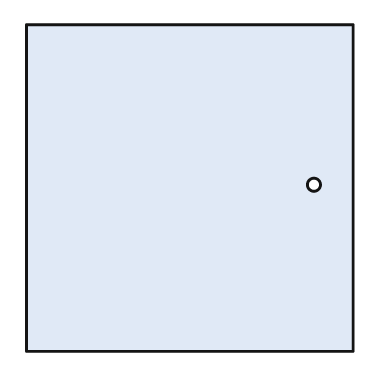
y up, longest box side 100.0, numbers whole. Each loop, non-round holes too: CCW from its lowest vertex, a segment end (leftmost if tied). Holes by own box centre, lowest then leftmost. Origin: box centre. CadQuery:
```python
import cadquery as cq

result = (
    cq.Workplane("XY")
    .moveTo(-50.0, -50.0)
    .lineTo(50.0, -50.0)
    .lineTo(50.0, 50.0)
    .lineTo(-50.0, 50.0)
    .close()
    .moveTo(38.0, 1.0)
    .circle(2.0)
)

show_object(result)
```